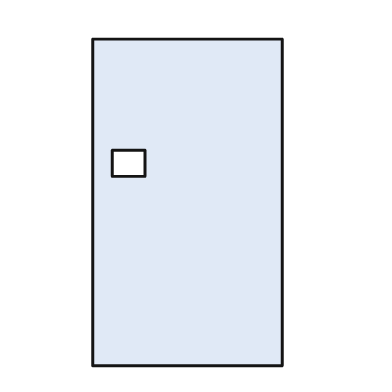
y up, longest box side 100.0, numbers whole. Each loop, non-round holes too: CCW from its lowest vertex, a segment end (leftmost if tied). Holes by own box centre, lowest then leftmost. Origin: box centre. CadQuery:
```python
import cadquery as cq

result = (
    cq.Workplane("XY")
    .moveTo(-29.0, -50.0)
    .lineTo(29.0, -50.0)
    .lineTo(29.0, 50.0)
    .lineTo(-29.0, 50.0)
    .close()
    .moveTo(-23.0, 8.0)
    .lineTo(-13.0, 8.0)
    .lineTo(-13.0, 16.0)
    .lineTo(-23.0, 16.0)
    .close()
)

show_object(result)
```